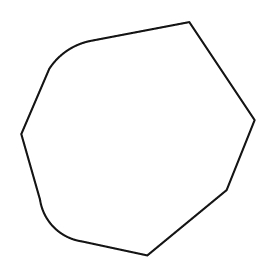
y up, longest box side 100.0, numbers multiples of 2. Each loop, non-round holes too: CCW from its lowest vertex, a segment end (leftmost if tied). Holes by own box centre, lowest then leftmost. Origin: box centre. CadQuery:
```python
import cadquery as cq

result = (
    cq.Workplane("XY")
    .moveTo(4.0, -50.0)
    .lineTo(38.0, -22.0)
    .lineTo(50.0, 8.0)
    .lineTo(22.0, 50.0)
    .lineTo(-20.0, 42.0)
    .threePointArc((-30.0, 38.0), (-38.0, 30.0))
    .lineTo(-50.0, 2.0)
    .lineTo(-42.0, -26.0)
    .threePointArc((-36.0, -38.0), (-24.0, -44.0))
    .close()
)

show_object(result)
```